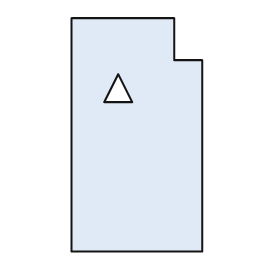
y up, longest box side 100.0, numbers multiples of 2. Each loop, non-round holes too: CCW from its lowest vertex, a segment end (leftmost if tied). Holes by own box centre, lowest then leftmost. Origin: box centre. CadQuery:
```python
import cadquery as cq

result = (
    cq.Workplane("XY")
    .moveTo(-28.0, -50.0)
    .lineTo(28.0, -50.0)
    .lineTo(28.0, 32.0)
    .lineTo(16.0, 32.0)
    .lineTo(16.0, 50.0)
    .lineTo(-28.0, 50.0)
    .close()
    .moveTo(-14.0, 14.0)
    .lineTo(-2.0, 14.0)
    .lineTo(-8.0, 26.0)
    .close()
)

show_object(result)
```